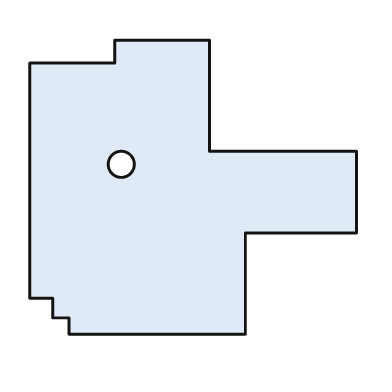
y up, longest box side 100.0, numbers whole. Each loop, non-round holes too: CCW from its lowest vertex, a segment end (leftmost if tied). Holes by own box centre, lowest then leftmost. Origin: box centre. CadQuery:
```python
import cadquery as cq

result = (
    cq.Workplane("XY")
    .moveTo(-38.0, -45.0)
    .lineTo(16.0, -45.0)
    .lineTo(16.0, -14.0)
    .lineTo(50.0, -14.0)
    .lineTo(50.0, 11.0)
    .lineTo(5.0, 11.0)
    .lineTo(5.0, 45.0)
    .lineTo(-24.0, 45.0)
    .lineTo(-24.0, 38.0)
    .lineTo(-50.0, 38.0)
    .lineTo(-50.0, -34.0)
    .lineTo(-43.0, -34.0)
    .lineTo(-43.0, -40.0)
    .lineTo(-38.0, -40.0)
    .close()
    .moveTo(-22.0, 7.0)
    .circle(4.0)
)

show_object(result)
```